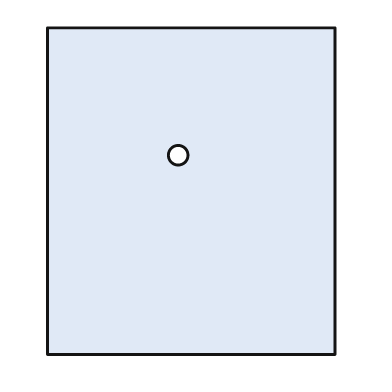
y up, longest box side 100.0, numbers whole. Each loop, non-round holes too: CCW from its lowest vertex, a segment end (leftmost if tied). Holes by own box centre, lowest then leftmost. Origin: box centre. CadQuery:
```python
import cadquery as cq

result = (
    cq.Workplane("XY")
    .moveTo(-44.0, -50.0)
    .lineTo(44.0, -50.0)
    .lineTo(44.0, 50.0)
    .lineTo(-44.0, 50.0)
    .close()
    .moveTo(-4.0, 11.0)
    .circle(3.0)
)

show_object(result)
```